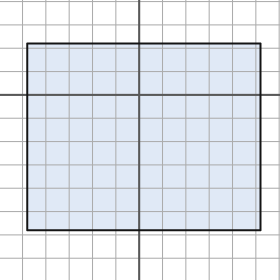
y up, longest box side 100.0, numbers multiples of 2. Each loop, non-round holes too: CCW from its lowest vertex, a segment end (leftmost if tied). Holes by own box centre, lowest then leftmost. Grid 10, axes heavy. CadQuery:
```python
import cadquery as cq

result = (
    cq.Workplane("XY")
    .moveTo(-48.0, -58.0)
    .lineTo(52.0, -58.0)
    .lineTo(52.0, 22.0)
    .lineTo(-48.0, 22.0)
    .close()
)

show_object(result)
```